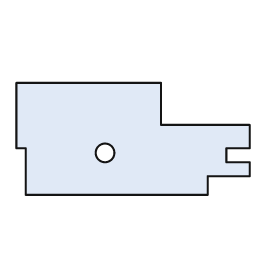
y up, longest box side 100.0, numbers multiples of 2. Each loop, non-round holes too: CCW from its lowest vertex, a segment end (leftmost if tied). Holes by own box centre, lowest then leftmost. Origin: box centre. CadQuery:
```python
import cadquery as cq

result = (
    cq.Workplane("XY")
    .moveTo(-46.0, -24.0)
    .lineTo(32.0, -24.0)
    .lineTo(32.0, -16.0)
    .lineTo(50.0, -16.0)
    .lineTo(50.0, -10.0)
    .lineTo(40.0, -10.0)
    .lineTo(40.0, -4.0)
    .lineTo(50.0, -4.0)
    .lineTo(50.0, 6.0)
    .lineTo(12.0, 6.0)
    .lineTo(12.0, 24.0)
    .lineTo(-50.0, 24.0)
    .lineTo(-50.0, -4.0)
    .lineTo(-46.0, -4.0)
    .close()
    .moveTo(-12.0, -6.0)
    .circle(4.0)
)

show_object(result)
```